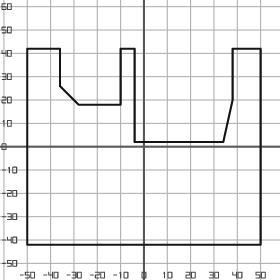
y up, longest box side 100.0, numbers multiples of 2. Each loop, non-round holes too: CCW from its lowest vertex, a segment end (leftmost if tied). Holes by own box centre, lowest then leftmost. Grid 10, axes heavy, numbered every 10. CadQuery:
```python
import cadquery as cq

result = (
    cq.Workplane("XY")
    .moveTo(-50.0, -42.0)
    .lineTo(50.0, -42.0)
    .lineTo(50.0, 42.0)
    .lineTo(38.0, 42.0)
    .lineTo(38.0, 20.0)
    .lineTo(34.0, 2.0)
    .lineTo(-4.0, 2.0)
    .lineTo(-4.0, 42.0)
    .lineTo(-10.0, 42.0)
    .lineTo(-10.0, 18.0)
    .lineTo(-28.0, 18.0)
    .lineTo(-36.0, 26.0)
    .lineTo(-36.0, 42.0)
    .lineTo(-50.0, 42.0)
    .close()
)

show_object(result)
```